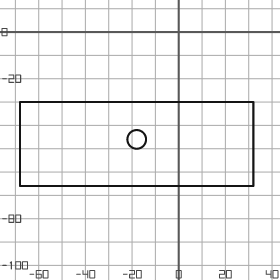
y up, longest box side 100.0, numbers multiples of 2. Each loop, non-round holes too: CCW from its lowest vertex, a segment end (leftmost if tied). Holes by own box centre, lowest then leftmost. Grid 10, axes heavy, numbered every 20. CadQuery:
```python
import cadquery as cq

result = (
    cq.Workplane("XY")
    .moveTo(-68.0, -66.0)
    .lineTo(32.0, -66.0)
    .lineTo(32.0, -30.0)
    .lineTo(-68.0, -30.0)
    .close()
    .moveTo(-18.0, -46.0)
    .circle(4.0)
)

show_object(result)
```